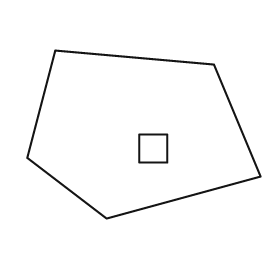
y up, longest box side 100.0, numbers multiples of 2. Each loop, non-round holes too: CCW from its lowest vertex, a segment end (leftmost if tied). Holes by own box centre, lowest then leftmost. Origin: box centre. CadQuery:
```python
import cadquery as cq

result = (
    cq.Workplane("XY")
    .moveTo(-16.0, -36.0)
    .lineTo(50.0, -18.0)
    .lineTo(30.0, 30.0)
    .lineTo(-38.0, 36.0)
    .lineTo(-50.0, -10.0)
    .close()
    .moveTo(-2.0, -12.0)
    .lineTo(10.0, -12.0)
    .lineTo(10.0, 0.0)
    .lineTo(-2.0, 0.0)
    .close()
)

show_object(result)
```